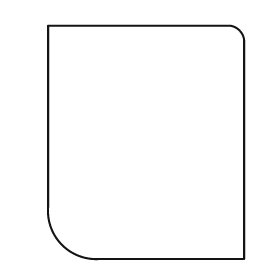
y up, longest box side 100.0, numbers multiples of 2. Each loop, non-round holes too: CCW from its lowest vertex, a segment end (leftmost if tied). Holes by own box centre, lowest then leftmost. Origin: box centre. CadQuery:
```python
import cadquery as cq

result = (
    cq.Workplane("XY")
    .moveTo(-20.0, -50.0)
    .lineTo(42.0, -50.0)
    .lineTo(42.0, 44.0)
    .threePointArc((40.0, 48.0), (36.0, 50.0))
    .lineTo(-42.0, 50.0)
    .lineTo(-42.0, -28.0)
    .threePointArc((-36.0, -44.0), (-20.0, -50.0))
    .close()
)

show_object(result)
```